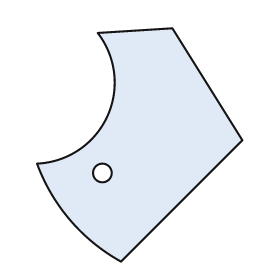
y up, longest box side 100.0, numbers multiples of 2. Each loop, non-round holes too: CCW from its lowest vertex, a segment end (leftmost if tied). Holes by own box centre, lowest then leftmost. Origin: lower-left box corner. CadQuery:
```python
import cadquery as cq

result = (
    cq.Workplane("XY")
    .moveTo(36.0, 0.0)
    .lineTo(88.0, 52.0)
    .lineTo(58.0, 100.0)
    .lineTo(26.0, 98.0)
    .threePointArc((30.0, 62.0), (0.0, 42.0))
    .threePointArc((14.0, 18.0), (36.0, 0.0))
    .close()
    .moveTo(28.0, 38.0)
    .circle(4.0)
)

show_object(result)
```